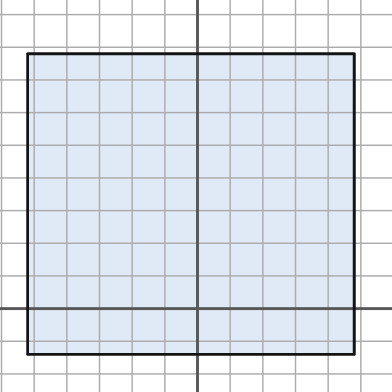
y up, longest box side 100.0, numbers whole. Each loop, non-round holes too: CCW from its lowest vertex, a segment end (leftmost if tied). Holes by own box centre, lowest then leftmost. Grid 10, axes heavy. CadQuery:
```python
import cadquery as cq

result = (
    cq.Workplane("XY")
    .moveTo(-52.0, -14.0)
    .lineTo(48.0, -14.0)
    .lineTo(48.0, 78.0)
    .lineTo(-52.0, 78.0)
    .close()
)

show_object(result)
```